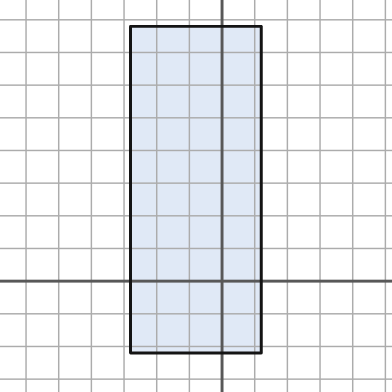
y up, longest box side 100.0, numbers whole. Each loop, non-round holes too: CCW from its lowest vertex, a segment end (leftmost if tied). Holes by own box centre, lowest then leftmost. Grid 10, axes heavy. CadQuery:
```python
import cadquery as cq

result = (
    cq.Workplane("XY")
    .moveTo(-28.0, -22.0)
    .lineTo(12.0, -22.0)
    .lineTo(12.0, 78.0)
    .lineTo(-28.0, 78.0)
    .close()
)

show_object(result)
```